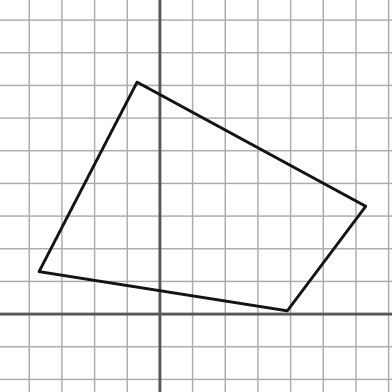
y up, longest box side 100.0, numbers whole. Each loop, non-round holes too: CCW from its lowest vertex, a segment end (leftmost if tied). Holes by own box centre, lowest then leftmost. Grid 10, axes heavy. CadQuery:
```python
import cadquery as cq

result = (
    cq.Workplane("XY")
    .moveTo(39.0, 1.0)
    .lineTo(63.0, 33.0)
    .lineTo(-7.0, 71.0)
    .lineTo(-37.0, 13.0)
    .close()
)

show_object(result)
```